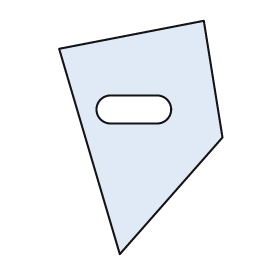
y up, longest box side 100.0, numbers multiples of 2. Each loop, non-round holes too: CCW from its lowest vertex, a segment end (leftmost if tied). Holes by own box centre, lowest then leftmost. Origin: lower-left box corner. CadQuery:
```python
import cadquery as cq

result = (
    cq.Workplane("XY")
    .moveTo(26.0, 0.0)
    .lineTo(70.0, 50.0)
    .lineTo(62.0, 100.0)
    .lineTo(0.0, 88.0)
    .close()
    .moveTo(22.0, 56.0)
    .lineTo(42.0, 56.0)
    .threePointArc((48.0, 62.0), (42.0, 68.0))
    .lineTo(22.0, 68.0)
    .threePointArc((16.0, 62.0), (22.0, 56.0))
    .close()
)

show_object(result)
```